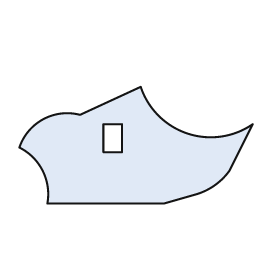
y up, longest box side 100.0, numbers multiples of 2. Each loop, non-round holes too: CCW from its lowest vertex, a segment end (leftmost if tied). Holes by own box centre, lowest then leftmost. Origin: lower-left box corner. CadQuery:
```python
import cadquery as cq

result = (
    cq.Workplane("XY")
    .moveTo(12.0, 0.0)
    .lineTo(62.0, 0.0)
    .lineTo(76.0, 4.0)
    .threePointArc((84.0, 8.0), (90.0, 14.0))
    .lineTo(100.0, 34.0)
    .threePointArc((72.0, 30.0), (52.0, 50.0))
    .lineTo(26.0, 38.0)
    .threePointArc((10.0, 36.0), (0.0, 24.0))
    .threePointArc((10.0, 14.0), (12.0, 0.0))
    .close()
    .moveTo(36.0, 22.0)
    .lineTo(44.0, 22.0)
    .lineTo(44.0, 34.0)
    .lineTo(36.0, 34.0)
    .close()
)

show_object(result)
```